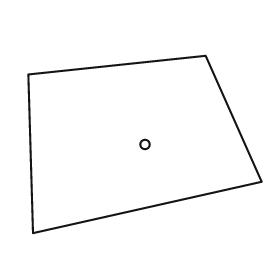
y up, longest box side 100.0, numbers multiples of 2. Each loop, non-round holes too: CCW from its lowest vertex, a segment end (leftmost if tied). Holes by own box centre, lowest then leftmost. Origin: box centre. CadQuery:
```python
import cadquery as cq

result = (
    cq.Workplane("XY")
    .moveTo(-48.0, -38.0)
    .lineTo(50.0, -16.0)
    .lineTo(26.0, 38.0)
    .lineTo(-50.0, 30.0)
    .close()
    .moveTo(0.0, 0.0)
    .circle(2.0)
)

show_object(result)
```